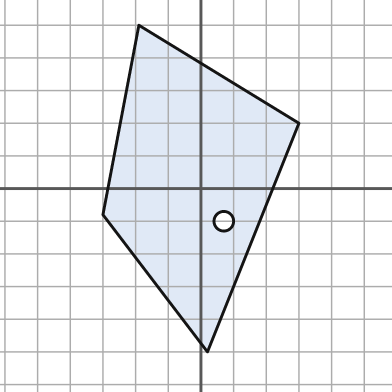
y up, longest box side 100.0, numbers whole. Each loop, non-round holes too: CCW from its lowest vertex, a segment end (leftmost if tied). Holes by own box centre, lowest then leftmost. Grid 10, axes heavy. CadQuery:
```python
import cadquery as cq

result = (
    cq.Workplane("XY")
    .moveTo(2.0, -50.0)
    .lineTo(30.0, 20.0)
    .lineTo(-19.0, 50.0)
    .lineTo(-30.0, -8.0)
    .close()
    .moveTo(7.0, -10.0)
    .circle(3.0)
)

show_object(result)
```